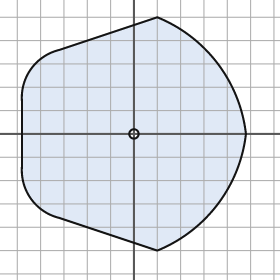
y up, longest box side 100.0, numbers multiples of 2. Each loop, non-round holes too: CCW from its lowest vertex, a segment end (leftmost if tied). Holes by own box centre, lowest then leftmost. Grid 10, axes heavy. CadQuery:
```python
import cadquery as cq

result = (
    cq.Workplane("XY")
    .moveTo(10.0, -50.0)
    .threePointArc((36.0, -30.0), (48.0, 0.0))
    .threePointArc((36.0, 30.0), (10.0, 50.0))
    .lineTo(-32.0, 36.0)
    .threePointArc((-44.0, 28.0), (-48.0, 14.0))
    .lineTo(-48.0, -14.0)
    .threePointArc((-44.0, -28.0), (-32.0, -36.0))
    .close()
    .moveTo(0.0, 0.0)
    .circle(2.0)
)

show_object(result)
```